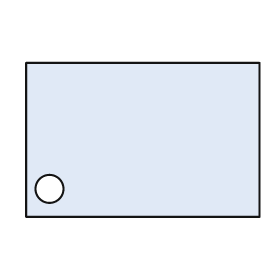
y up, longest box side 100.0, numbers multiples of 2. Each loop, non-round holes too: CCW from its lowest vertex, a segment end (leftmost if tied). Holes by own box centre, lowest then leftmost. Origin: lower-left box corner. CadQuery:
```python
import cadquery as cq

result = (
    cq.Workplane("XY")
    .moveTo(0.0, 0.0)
    .lineTo(100.0, 0.0)
    .lineTo(100.0, 66.0)
    .lineTo(0.0, 66.0)
    .close()
    .moveTo(10.0, 12.0)
    .circle(6.0)
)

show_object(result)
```